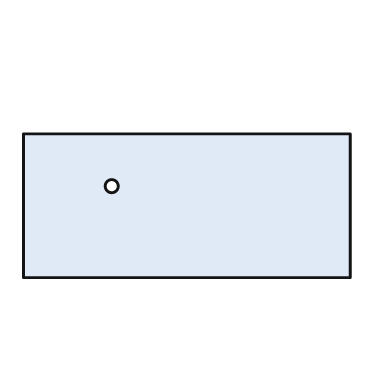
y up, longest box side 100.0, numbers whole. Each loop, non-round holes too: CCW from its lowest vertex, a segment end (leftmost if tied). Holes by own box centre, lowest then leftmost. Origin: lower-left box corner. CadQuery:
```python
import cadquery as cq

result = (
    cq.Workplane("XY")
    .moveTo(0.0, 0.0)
    .lineTo(100.0, 0.0)
    .lineTo(100.0, 44.0)
    .lineTo(0.0, 44.0)
    .close()
    .moveTo(27.0, 28.0)
    .circle(2.0)
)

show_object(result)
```